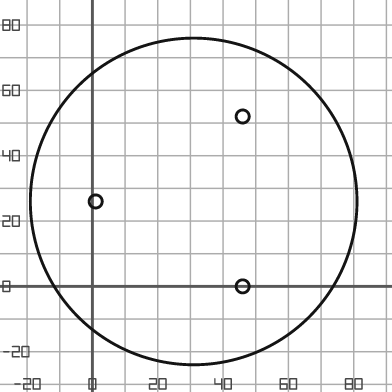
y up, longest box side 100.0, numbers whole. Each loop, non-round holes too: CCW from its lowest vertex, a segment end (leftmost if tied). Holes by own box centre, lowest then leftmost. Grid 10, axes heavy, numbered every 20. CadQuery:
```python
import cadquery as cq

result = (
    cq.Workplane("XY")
    .moveTo(31.0, 26.0)
    .circle(50.0)
    .moveTo(46.0, 0.0)
    .circle(2.0)
    .moveTo(1.0, 26.0)
    .circle(2.0)
    .moveTo(46.0, 52.0)
    .circle(2.0)
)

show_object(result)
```